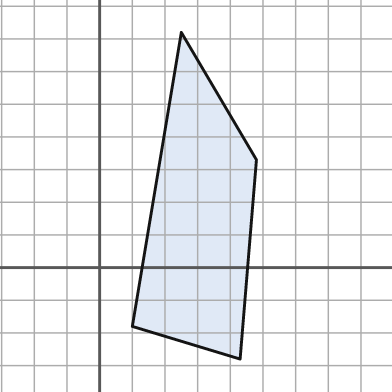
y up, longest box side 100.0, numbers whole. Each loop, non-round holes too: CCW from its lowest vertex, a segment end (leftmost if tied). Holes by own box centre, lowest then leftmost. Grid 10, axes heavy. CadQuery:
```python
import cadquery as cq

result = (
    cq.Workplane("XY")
    .moveTo(43.0, -28.0)
    .lineTo(48.0, 33.0)
    .lineTo(25.0, 72.0)
    .lineTo(10.0, -18.0)
    .close()
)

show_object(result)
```